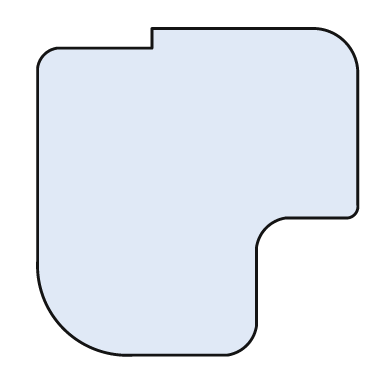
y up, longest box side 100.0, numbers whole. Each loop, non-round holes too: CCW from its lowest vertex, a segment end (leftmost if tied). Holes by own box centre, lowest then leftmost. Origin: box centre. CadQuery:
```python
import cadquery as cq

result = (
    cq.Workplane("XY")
    .moveTo(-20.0, -50.0)
    .lineTo(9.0, -50.0)
    .threePointArc((15.0, -47.0), (18.0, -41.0))
    .lineTo(18.0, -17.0)
    .threePointArc((21.0, -11.0), (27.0, -8.0))
    .lineTo(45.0, -8.0)
    .threePointArc((48.0, -7.0), (49.0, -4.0))
    .lineTo(49.0, 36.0)
    .threePointArc((45.0, 46.0), (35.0, 50.0))
    .lineTo(-14.0, 50.0)
    .lineTo(-14.0, 44.0)
    .lineTo(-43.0, 44.0)
    .threePointArc((-47.0, 42.0), (-49.0, 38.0))
    .lineTo(-49.0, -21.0)
    .threePointArc((-41.0, -42.0), (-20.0, -50.0))
    .close()
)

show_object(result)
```